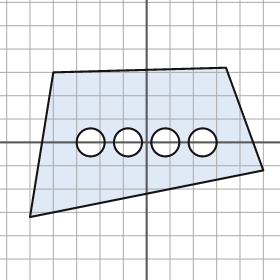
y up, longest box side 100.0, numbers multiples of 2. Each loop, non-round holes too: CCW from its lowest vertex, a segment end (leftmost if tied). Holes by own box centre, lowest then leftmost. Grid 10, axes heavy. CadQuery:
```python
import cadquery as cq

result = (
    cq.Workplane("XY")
    .moveTo(-50.0, -32.0)
    .lineTo(50.0, -12.0)
    .lineTo(34.0, 32.0)
    .lineTo(-40.0, 30.0)
    .close()
    .moveTo(-24.0, 0.0)
    .circle(6.0)
    .moveTo(-8.0, 0.0)
    .circle(6.0)
    .moveTo(8.0, 0.0)
    .circle(6.0)
    .moveTo(24.0, 0.0)
    .circle(6.0)
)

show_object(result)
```